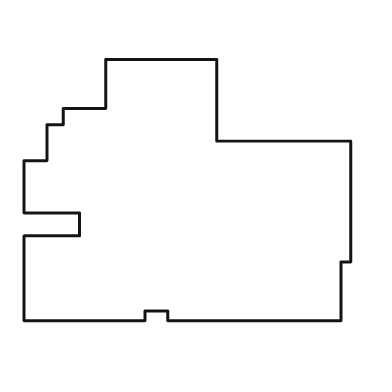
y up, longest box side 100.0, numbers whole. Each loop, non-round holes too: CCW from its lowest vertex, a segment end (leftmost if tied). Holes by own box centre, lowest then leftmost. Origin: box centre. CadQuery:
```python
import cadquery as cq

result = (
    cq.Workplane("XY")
    .moveTo(-50.0, -40.0)
    .lineTo(-13.0, -40.0)
    .lineTo(-13.0, -37.0)
    .lineTo(-6.0, -37.0)
    .lineTo(-6.0, -40.0)
    .lineTo(47.0, -40.0)
    .lineTo(47.0, -22.0)
    .lineTo(50.0, -22.0)
    .lineTo(50.0, 15.0)
    .lineTo(9.0, 15.0)
    .lineTo(9.0, 40.0)
    .lineTo(-25.0, 40.0)
    .lineTo(-25.0, 25.0)
    .lineTo(-38.0, 25.0)
    .lineTo(-38.0, 20.0)
    .lineTo(-43.0, 20.0)
    .lineTo(-43.0, 9.0)
    .lineTo(-50.0, 9.0)
    .lineTo(-50.0, -7.0)
    .lineTo(-33.0, -7.0)
    .lineTo(-33.0, -14.0)
    .lineTo(-50.0, -14.0)
    .close()
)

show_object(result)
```